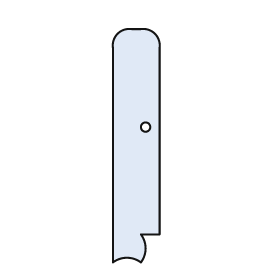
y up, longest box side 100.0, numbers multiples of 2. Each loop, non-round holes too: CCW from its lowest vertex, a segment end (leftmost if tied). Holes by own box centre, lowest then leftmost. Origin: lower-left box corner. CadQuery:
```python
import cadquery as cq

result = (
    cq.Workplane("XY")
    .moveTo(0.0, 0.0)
    .threePointArc((6.0, 2.0), (12.0, 0.0))
    .threePointArc((14.0, 6.0), (12.0, 12.0))
    .lineTo(20.0, 12.0)
    .lineTo(20.0, 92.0)
    .threePointArc((18.0, 98.0), (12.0, 100.0))
    .lineTo(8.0, 100.0)
    .threePointArc((2.0, 98.0), (0.0, 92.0))
    .close()
    .moveTo(14.0, 58.0)
    .circle(2.0)
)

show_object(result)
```